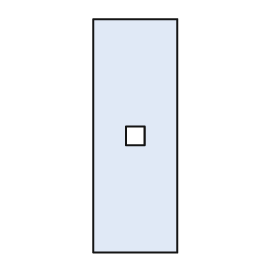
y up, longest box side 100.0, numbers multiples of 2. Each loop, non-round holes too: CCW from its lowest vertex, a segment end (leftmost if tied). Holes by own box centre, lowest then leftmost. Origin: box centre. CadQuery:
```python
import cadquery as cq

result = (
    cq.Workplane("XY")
    .moveTo(-18.0, -50.0)
    .lineTo(18.0, -50.0)
    .lineTo(18.0, 50.0)
    .lineTo(-18.0, 50.0)
    .close()
    .moveTo(-4.0, -4.0)
    .lineTo(4.0, -4.0)
    .lineTo(4.0, 4.0)
    .lineTo(-4.0, 4.0)
    .close()
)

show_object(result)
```